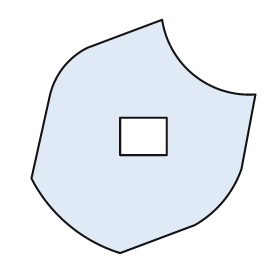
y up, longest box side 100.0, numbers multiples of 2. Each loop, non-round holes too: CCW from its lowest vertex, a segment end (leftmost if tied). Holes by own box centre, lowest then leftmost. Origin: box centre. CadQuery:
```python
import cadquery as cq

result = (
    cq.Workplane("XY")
    .moveTo(-10.0, -50.0)
    .lineTo(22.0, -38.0)
    .threePointArc((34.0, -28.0), (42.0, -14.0))
    .lineTo(48.0, 18.0)
    .threePointArc((22.0, 26.0), (8.0, 50.0))
    .lineTo(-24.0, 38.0)
    .threePointArc((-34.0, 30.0), (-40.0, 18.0))
    .lineTo(-48.0, -18.0)
    .threePointArc((-32.0, -38.0), (-10.0, -50.0))
    .close()
    .moveTo(-10.0, -8.0)
    .lineTo(10.0, -8.0)
    .lineTo(10.0, 8.0)
    .lineTo(-10.0, 8.0)
    .close()
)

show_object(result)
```